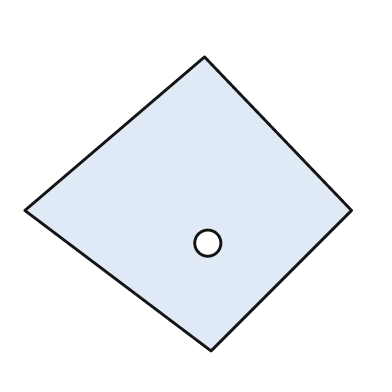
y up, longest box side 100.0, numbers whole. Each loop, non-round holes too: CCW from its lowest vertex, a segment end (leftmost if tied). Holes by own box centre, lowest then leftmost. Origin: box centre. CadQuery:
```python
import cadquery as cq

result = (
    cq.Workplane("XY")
    .moveTo(7.0, -45.0)
    .lineTo(50.0, -2.0)
    .lineTo(5.0, 45.0)
    .lineTo(-50.0, -2.0)
    .close()
    .moveTo(6.0, -12.0)
    .circle(4.0)
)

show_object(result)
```